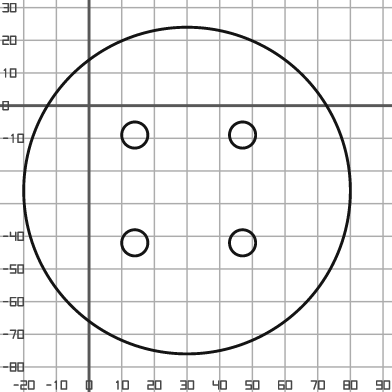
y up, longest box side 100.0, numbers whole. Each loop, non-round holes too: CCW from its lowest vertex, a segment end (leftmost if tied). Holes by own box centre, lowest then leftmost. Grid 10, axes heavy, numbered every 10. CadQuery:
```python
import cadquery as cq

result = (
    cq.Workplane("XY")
    .moveTo(30.0, -26.0)
    .circle(50.0)
    .moveTo(14.0, -42.0)
    .circle(4.0)
    .moveTo(47.0, -42.0)
    .circle(4.0)
    .moveTo(14.0, -9.0)
    .circle(4.0)
    .moveTo(47.0, -9.0)
    .circle(4.0)
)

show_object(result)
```